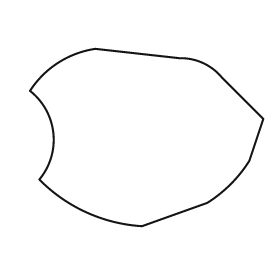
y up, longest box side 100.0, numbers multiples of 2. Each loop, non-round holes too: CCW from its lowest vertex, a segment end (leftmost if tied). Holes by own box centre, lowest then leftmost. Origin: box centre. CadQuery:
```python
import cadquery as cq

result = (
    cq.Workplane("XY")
    .moveTo(-2.0, -38.0)
    .lineTo(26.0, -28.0)
    .threePointArc((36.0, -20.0), (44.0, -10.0))
    .lineTo(50.0, 8.0)
    .lineTo(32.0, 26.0)
    .threePointArc((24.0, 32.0), (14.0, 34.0))
    .lineTo(-22.0, 38.0)
    .threePointArc((-38.0, 32.0), (-50.0, 20.0))
    .threePointArc((-40.0, 2.0), (-46.0, -18.0))
    .threePointArc((-26.0, -32.0), (-2.0, -38.0))
    .close()
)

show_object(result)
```